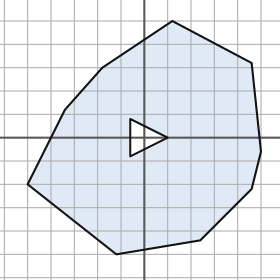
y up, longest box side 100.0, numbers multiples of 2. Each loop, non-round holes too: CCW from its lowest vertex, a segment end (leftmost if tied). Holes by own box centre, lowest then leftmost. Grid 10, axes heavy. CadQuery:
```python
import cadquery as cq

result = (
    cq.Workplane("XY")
    .moveTo(-12.0, -50.0)
    .lineTo(24.0, -44.0)
    .lineTo(46.0, -22.0)
    .lineTo(50.0, -6.0)
    .lineTo(46.0, 32.0)
    .lineTo(12.0, 50.0)
    .lineTo(-18.0, 30.0)
    .lineTo(-34.0, 12.0)
    .lineTo(-50.0, -20.0)
    .close()
    .moveTo(-6.0, -8.0)
    .lineTo(10.0, 0.0)
    .lineTo(-6.0, 8.0)
    .close()
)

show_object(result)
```